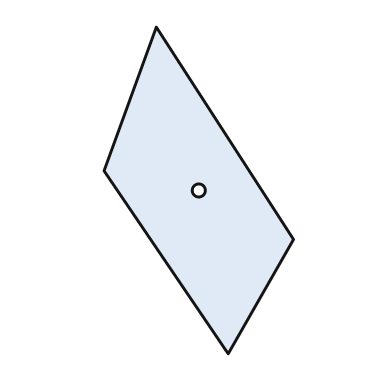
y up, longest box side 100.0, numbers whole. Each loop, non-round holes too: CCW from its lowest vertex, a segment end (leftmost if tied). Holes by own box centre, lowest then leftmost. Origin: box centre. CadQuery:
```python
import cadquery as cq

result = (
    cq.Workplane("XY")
    .moveTo(9.0, -50.0)
    .lineTo(29.0, -15.0)
    .lineTo(-13.0, 50.0)
    .lineTo(-29.0, 6.0)
    .close()
    .moveTo(0.0, 0.0)
    .circle(2.0)
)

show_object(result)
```